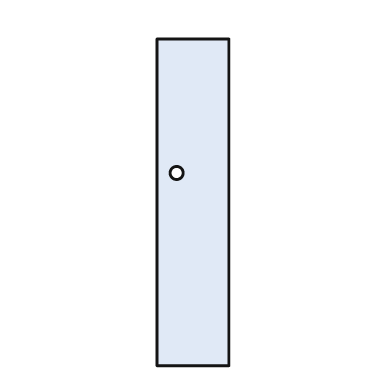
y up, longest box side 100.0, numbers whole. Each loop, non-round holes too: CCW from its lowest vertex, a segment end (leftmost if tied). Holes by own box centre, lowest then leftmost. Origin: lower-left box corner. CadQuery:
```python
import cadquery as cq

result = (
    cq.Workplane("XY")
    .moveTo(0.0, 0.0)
    .lineTo(22.0, 0.0)
    .lineTo(22.0, 100.0)
    .lineTo(0.0, 100.0)
    .close()
    .moveTo(6.0, 59.0)
    .circle(2.0)
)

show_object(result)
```